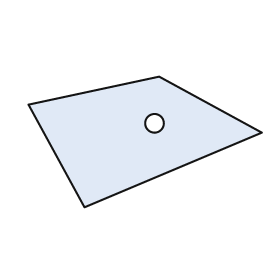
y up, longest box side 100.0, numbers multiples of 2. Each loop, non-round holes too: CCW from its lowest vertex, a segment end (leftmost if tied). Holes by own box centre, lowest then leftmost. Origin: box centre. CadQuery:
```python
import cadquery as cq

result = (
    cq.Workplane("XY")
    .moveTo(-26.0, -28.0)
    .lineTo(50.0, 4.0)
    .lineTo(6.0, 28.0)
    .lineTo(-50.0, 16.0)
    .close()
    .moveTo(4.0, 8.0)
    .circle(4.0)
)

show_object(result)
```